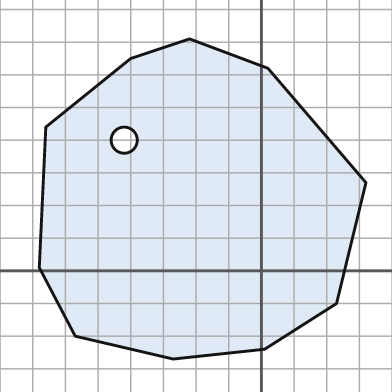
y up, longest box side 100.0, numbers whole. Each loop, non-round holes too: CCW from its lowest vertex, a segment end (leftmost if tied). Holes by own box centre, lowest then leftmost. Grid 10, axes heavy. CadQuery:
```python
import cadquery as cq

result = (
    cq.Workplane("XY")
    .moveTo(-27.0, -27.0)
    .lineTo(1.0, -24.0)
    .lineTo(23.0, -10.0)
    .lineTo(32.0, 27.0)
    .lineTo(2.0, 62.0)
    .lineTo(-22.0, 71.0)
    .lineTo(-40.0, 65.0)
    .lineTo(-66.0, 44.0)
    .lineTo(-68.0, 1.0)
    .lineTo(-57.0, -20.0)
    .close()
    .moveTo(-42.0, 40.0)
    .circle(4.0)
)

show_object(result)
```